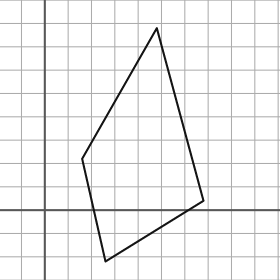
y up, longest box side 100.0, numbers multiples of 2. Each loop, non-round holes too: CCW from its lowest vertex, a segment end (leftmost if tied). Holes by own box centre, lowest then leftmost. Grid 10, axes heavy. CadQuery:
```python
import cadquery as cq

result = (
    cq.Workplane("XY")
    .moveTo(26.0, -22.0)
    .lineTo(68.0, 4.0)
    .lineTo(48.0, 78.0)
    .lineTo(16.0, 22.0)
    .close()
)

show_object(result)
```